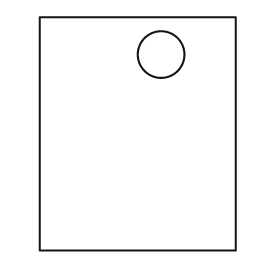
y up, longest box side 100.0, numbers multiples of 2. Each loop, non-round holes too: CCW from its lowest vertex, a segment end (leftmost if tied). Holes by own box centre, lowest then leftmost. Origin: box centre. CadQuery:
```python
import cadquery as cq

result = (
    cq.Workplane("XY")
    .moveTo(-42.0, -50.0)
    .lineTo(42.0, -50.0)
    .lineTo(42.0, 50.0)
    .lineTo(-42.0, 50.0)
    .close()
    .moveTo(10.0, 34.0)
    .circle(10.0)
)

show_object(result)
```